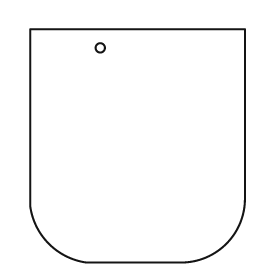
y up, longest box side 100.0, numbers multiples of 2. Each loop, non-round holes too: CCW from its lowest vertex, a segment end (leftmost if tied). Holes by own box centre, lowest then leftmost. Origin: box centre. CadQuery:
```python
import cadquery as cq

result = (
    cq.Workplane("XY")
    .moveTo(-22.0, -50.0)
    .lineTo(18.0, -50.0)
    .threePointArc((38.0, -42.0), (46.0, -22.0))
    .lineTo(46.0, 50.0)
    .lineTo(-46.0, 50.0)
    .lineTo(-46.0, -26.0)
    .threePointArc((-38.0, -42.0), (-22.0, -50.0))
    .close()
    .moveTo(-16.0, 42.0)
    .circle(2.0)
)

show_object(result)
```